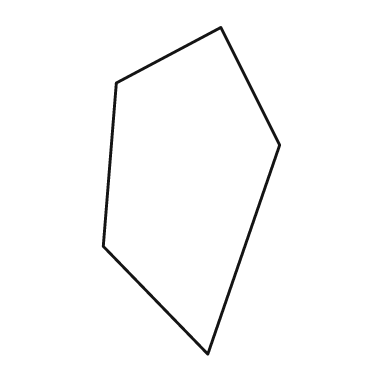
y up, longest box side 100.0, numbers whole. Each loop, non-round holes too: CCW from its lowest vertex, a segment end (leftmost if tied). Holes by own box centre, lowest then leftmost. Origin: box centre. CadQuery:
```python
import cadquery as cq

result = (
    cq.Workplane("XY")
    .moveTo(5.0, -50.0)
    .lineTo(27.0, 14.0)
    .lineTo(9.0, 50.0)
    .lineTo(-23.0, 33.0)
    .lineTo(-27.0, -17.0)
    .close()
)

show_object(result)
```